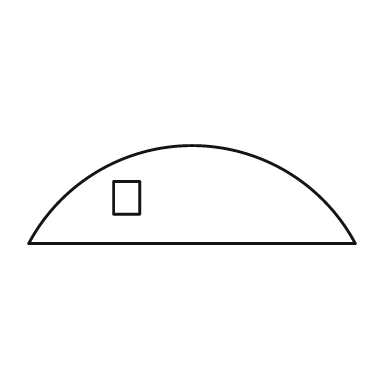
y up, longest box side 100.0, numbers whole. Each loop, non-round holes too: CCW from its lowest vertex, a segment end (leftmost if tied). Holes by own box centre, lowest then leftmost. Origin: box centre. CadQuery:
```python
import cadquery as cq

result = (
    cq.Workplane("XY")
    .moveTo(-50.0, -15.0)
    .lineTo(50.0, -15.0)
    .threePointArc((0.0, 15.0), (-50.0, -15.0))
    .close()
    .moveTo(-24.0, -6.0)
    .lineTo(-16.0, -6.0)
    .lineTo(-16.0, 4.0)
    .lineTo(-24.0, 4.0)
    .close()
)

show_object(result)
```